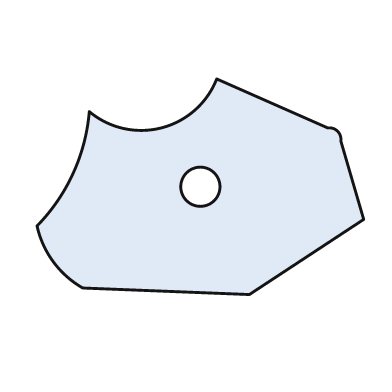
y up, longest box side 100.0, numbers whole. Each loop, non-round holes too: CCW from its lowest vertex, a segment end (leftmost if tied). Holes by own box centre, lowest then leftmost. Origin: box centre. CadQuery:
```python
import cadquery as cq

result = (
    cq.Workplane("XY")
    .moveTo(15.0, -33.0)
    .lineTo(50.0, -10.0)
    .lineTo(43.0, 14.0)
    .threePointArc((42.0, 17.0), (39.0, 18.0))
    .lineTo(5.0, 33.0)
    .threePointArc((-12.0, 18.0), (-34.0, 23.0))
    .threePointArc((-39.0, 4.0), (-50.0, -12.0))
    .threePointArc((-45.0, -23.0), (-36.0, -31.0))
    .close()
    .moveTo(0.0, 0.0)
    .circle(6.0)
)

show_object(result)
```